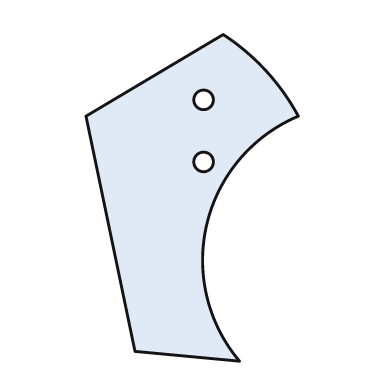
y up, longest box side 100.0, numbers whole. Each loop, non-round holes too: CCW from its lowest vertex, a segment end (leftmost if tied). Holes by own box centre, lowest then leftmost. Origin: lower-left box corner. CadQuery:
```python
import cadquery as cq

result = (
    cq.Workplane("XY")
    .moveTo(47.0, 0.0)
    .threePointArc((37.0, 42.0), (65.0, 75.0))
    .threePointArc((55.0, 89.0), (42.0, 100.0))
    .lineTo(0.0, 75.0)
    .lineTo(15.0, 3.0)
    .close()
    .moveTo(36.0, 61.0)
    .circle(3.0)
    .moveTo(36.0, 80.0)
    .circle(3.0)
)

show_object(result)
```